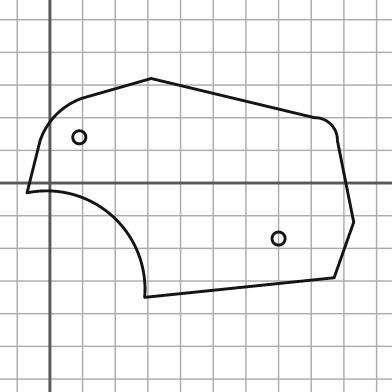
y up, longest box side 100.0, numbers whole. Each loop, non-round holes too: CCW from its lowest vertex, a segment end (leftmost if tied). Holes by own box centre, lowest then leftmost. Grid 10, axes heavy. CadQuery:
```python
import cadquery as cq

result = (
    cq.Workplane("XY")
    .moveTo(29.0, -35.0)
    .lineTo(87.0, -29.0)
    .lineTo(93.0, -12.0)
    .lineTo(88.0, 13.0)
    .threePointArc((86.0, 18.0), (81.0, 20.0))
    .lineTo(31.0, 32.0)
    .lineTo(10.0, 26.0)
    .threePointArc((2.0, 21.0), (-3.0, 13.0))
    .lineTo(-7.0, -3.0)
    .threePointArc((19.0, -10.0), (29.0, -35.0))
    .close()
    .moveTo(70.0, -17.0)
    .circle(2.0)
    .moveTo(9.0, 14.0)
    .circle(2.0)
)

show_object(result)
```